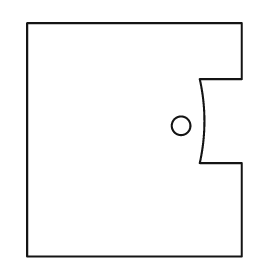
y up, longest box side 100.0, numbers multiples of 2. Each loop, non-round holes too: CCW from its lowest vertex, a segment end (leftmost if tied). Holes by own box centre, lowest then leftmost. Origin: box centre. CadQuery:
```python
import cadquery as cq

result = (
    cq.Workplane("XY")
    .moveTo(-46.0, -50.0)
    .lineTo(46.0, -50.0)
    .lineTo(46.0, -10.0)
    .lineTo(28.0, -10.0)
    .threePointArc((30.0, 8.0), (28.0, 26.0))
    .lineTo(46.0, 26.0)
    .lineTo(46.0, 50.0)
    .lineTo(-46.0, 50.0)
    .close()
    .moveTo(20.0, 6.0)
    .circle(4.0)
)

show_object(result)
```